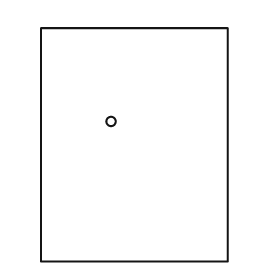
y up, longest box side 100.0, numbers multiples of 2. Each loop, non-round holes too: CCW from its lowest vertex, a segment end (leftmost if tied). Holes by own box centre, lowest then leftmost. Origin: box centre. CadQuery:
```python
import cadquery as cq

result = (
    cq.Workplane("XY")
    .moveTo(-40.0, -50.0)
    .lineTo(40.0, -50.0)
    .lineTo(40.0, 50.0)
    .lineTo(-40.0, 50.0)
    .close()
    .moveTo(-10.0, 10.0)
    .circle(2.0)
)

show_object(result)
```